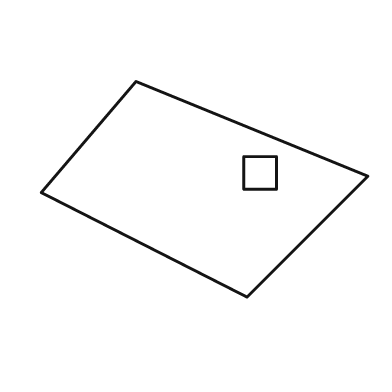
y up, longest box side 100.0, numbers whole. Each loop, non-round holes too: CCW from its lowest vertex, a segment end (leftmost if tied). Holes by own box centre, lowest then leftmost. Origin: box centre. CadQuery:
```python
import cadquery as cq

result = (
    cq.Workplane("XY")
    .moveTo(13.0, -33.0)
    .lineTo(50.0, 4.0)
    .lineTo(-21.0, 33.0)
    .lineTo(-50.0, -1.0)
    .close()
    .moveTo(12.0, 0.0)
    .lineTo(22.0, 0.0)
    .lineTo(22.0, 10.0)
    .lineTo(12.0, 10.0)
    .close()
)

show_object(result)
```